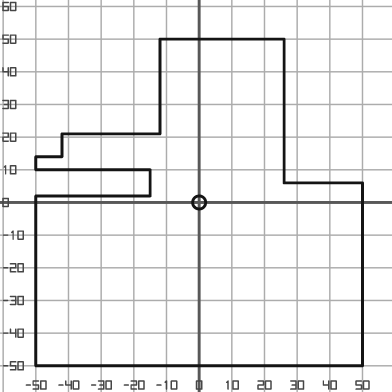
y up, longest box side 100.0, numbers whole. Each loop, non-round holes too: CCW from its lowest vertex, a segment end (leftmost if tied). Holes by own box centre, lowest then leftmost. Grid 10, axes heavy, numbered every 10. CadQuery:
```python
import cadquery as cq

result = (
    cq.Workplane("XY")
    .moveTo(-50.0, -50.0)
    .lineTo(50.0, -50.0)
    .lineTo(50.0, 6.0)
    .lineTo(26.0, 6.0)
    .lineTo(26.0, 50.0)
    .lineTo(-12.0, 50.0)
    .lineTo(-12.0, 21.0)
    .lineTo(-42.0, 21.0)
    .lineTo(-42.0, 14.0)
    .lineTo(-50.0, 14.0)
    .lineTo(-50.0, 10.0)
    .lineTo(-15.0, 10.0)
    .lineTo(-15.0, 2.0)
    .lineTo(-50.0, 2.0)
    .close()
    .moveTo(0.0, 0.0)
    .circle(2.0)
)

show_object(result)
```